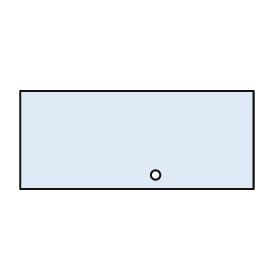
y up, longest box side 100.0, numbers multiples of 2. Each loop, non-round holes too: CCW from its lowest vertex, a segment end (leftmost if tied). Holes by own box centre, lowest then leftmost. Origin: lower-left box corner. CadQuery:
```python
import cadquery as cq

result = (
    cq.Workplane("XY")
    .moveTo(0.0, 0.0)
    .lineTo(100.0, 0.0)
    .lineTo(100.0, 42.0)
    .lineTo(0.0, 42.0)
    .close()
    .moveTo(58.0, 6.0)
    .circle(2.0)
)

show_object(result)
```